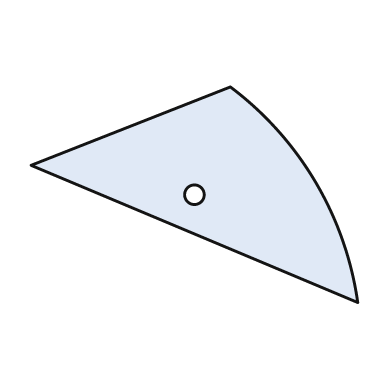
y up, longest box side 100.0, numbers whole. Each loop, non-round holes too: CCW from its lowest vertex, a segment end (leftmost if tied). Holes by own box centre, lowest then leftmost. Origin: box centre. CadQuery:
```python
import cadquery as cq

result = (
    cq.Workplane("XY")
    .moveTo(50.0, -33.0)
    .threePointArc((37.0, 4.0), (11.0, 33.0))
    .lineTo(-50.0, 9.0)
    .close()
    .moveTo(0.0, 0.0)
    .circle(3.0)
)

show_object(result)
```